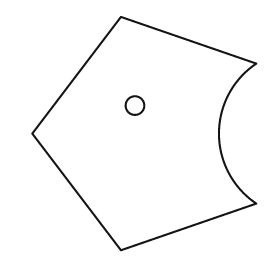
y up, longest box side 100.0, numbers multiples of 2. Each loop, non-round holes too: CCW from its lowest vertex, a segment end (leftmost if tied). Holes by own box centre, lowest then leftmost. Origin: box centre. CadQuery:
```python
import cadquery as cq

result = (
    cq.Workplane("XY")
    .moveTo(-10.0, -50.0)
    .lineTo(48.0, -30.0)
    .threePointArc((32.0, 0.0), (48.0, 30.0))
    .lineTo(-10.0, 50.0)
    .lineTo(-48.0, 0.0)
    .close()
    .moveTo(-4.0, 12.0)
    .circle(4.0)
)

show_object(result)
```